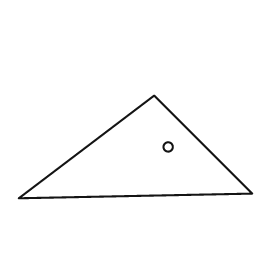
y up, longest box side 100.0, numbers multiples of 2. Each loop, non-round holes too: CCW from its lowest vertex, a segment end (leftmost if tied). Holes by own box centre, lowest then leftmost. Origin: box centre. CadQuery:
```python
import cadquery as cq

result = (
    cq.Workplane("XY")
    .moveTo(-50.0, -22.0)
    .lineTo(50.0, -20.0)
    .lineTo(8.0, 22.0)
    .close()
    .moveTo(14.0, 0.0)
    .circle(2.0)
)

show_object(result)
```